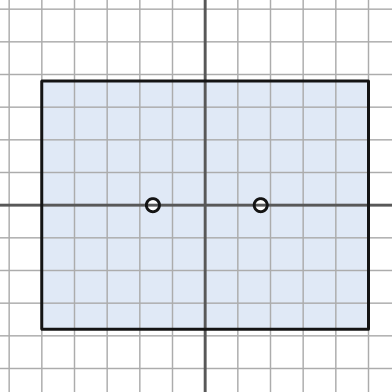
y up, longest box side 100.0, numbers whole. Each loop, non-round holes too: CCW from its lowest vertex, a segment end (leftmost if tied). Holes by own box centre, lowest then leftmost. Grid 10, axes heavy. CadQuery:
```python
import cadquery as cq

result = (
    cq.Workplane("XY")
    .moveTo(-50.0, -38.0)
    .lineTo(50.0, -38.0)
    .lineTo(50.0, 38.0)
    .lineTo(-50.0, 38.0)
    .close()
    .moveTo(-16.0, 0.0)
    .circle(2.0)
    .moveTo(17.0, 0.0)
    .circle(2.0)
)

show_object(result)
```